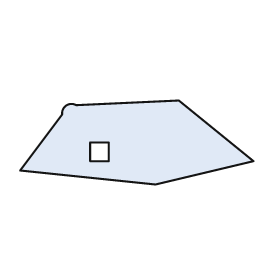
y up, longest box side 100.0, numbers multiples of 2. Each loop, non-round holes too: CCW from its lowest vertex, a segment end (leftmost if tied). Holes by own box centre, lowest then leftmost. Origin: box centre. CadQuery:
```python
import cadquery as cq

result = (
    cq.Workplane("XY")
    .moveTo(8.0, -18.0)
    .lineTo(50.0, -8.0)
    .lineTo(18.0, 18.0)
    .lineTo(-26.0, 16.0)
    .threePointArc((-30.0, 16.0), (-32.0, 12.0))
    .lineTo(-50.0, -12.0)
    .close()
    .moveTo(-20.0, -8.0)
    .lineTo(-12.0, -8.0)
    .lineTo(-12.0, 0.0)
    .lineTo(-20.0, 0.0)
    .close()
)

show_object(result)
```